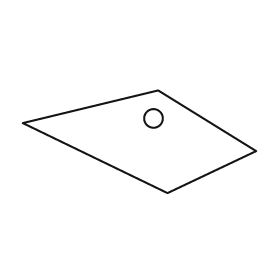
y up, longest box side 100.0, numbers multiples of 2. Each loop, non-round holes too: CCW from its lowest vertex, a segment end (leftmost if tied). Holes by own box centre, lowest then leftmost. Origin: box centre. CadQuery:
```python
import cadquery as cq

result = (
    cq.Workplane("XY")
    .moveTo(12.0, -22.0)
    .lineTo(50.0, -4.0)
    .lineTo(8.0, 22.0)
    .lineTo(-50.0, 8.0)
    .close()
    .moveTo(6.0, 10.0)
    .circle(4.0)
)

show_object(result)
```